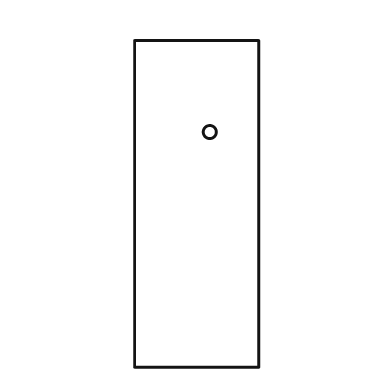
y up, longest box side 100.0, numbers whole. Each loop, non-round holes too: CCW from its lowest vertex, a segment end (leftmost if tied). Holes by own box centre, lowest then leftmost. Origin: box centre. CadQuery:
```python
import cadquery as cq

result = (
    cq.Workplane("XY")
    .moveTo(-19.0, -50.0)
    .lineTo(19.0, -50.0)
    .lineTo(19.0, 50.0)
    .lineTo(-19.0, 50.0)
    .close()
    .moveTo(4.0, 22.0)
    .circle(2.0)
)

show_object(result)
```